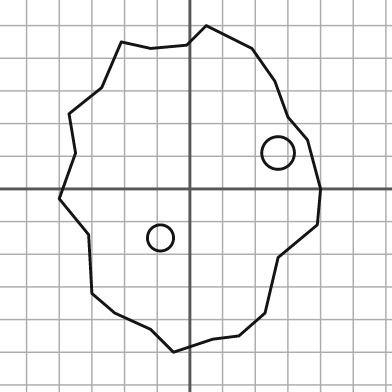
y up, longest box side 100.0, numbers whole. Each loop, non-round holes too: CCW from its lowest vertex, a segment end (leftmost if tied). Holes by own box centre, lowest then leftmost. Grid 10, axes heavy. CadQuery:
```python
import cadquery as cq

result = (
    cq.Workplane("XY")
    .moveTo(-5.0, -50.0)
    .lineTo(7.0, -46.0)
    .lineTo(15.0, -45.0)
    .lineTo(23.0, -38.0)
    .lineTo(27.0, -21.0)
    .lineTo(39.0, -11.0)
    .lineTo(40.0, 0.0)
    .lineTo(36.0, 15.0)
    .lineTo(30.0, 22.0)
    .lineTo(26.0, 33.0)
    .lineTo(19.0, 43.0)
    .lineTo(5.0, 50.0)
    .lineTo(-1.0, 44.0)
    .lineTo(-12.0, 43.0)
    .lineTo(-21.0, 45.0)
    .lineTo(-27.0, 31.0)
    .lineTo(-37.0, 23.0)
    .lineTo(-35.0, 11.0)
    .lineTo(-40.0, -3.0)
    .lineTo(-31.0, -14.0)
    .lineTo(-30.0, -32.0)
    .lineTo(-23.0, -38.0)
    .lineTo(-12.0, -43.0)
    .close()
    .moveTo(-9.0, -15.0)
    .circle(4.0)
    .moveTo(27.0, 11.0)
    .circle(5.0)
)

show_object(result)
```